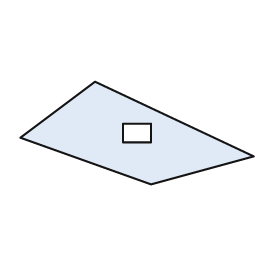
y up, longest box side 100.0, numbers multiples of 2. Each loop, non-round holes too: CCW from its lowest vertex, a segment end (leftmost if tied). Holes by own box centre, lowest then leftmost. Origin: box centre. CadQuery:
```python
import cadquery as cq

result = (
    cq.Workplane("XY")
    .moveTo(6.0, -22.0)
    .lineTo(50.0, -10.0)
    .lineTo(-18.0, 22.0)
    .lineTo(-50.0, -2.0)
    .close()
    .moveTo(-6.0, -4.0)
    .lineTo(6.0, -4.0)
    .lineTo(6.0, 4.0)
    .lineTo(-6.0, 4.0)
    .close()
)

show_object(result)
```